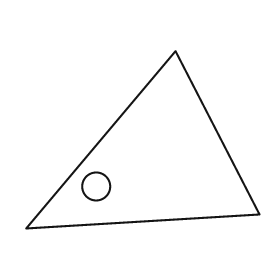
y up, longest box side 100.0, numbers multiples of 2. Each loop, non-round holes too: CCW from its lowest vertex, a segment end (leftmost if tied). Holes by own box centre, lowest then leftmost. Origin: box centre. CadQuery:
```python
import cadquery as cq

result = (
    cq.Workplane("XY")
    .moveTo(-50.0, -38.0)
    .lineTo(50.0, -32.0)
    .lineTo(14.0, 38.0)
    .close()
    .moveTo(-20.0, -20.0)
    .circle(6.0)
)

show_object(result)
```